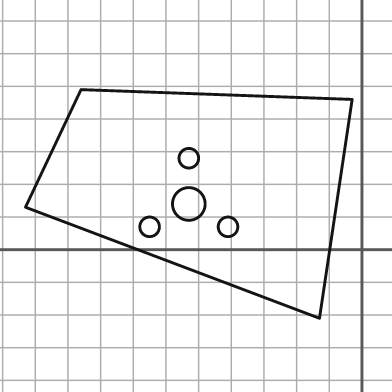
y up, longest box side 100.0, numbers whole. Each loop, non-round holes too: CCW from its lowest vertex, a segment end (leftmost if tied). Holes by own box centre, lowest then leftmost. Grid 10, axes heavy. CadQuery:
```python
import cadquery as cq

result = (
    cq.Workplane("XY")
    .moveTo(-13.0, -21.0)
    .lineTo(-3.0, 46.0)
    .lineTo(-86.0, 49.0)
    .lineTo(-103.0, 13.0)
    .close()
    .moveTo(-65.0, 7.0)
    .circle(3.0)
    .moveTo(-41.0, 7.0)
    .circle(3.0)
    .moveTo(-53.0, 14.0)
    .circle(5.0)
    .moveTo(-53.0, 28.0)
    .circle(3.0)
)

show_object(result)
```